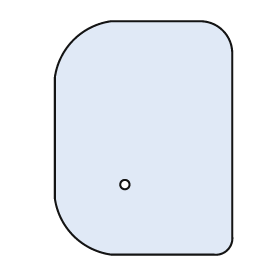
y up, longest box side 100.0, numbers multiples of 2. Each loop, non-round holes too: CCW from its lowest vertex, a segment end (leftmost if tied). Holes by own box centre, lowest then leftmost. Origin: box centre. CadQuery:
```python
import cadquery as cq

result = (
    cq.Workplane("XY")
    .moveTo(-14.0, -50.0)
    .lineTo(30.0, -50.0)
    .threePointArc((36.0, -48.0), (38.0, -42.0))
    .lineTo(38.0, 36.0)
    .threePointArc((34.0, 46.0), (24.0, 50.0))
    .lineTo(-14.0, 50.0)
    .threePointArc((-30.0, 42.0), (-38.0, 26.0))
    .lineTo(-38.0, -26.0)
    .threePointArc((-30.0, -42.0), (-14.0, -50.0))
    .close()
    .moveTo(-8.0, -20.0)
    .circle(2.0)
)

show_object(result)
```